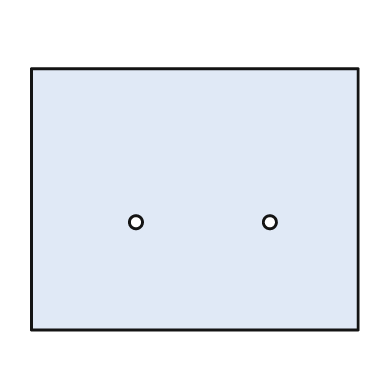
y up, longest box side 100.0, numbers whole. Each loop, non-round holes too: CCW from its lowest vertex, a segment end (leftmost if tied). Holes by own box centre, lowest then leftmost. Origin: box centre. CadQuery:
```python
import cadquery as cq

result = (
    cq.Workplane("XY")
    .moveTo(-50.0, -40.0)
    .lineTo(50.0, -40.0)
    .lineTo(50.0, 40.0)
    .lineTo(-50.0, 40.0)
    .close()
    .moveTo(-18.0, -7.0)
    .circle(2.0)
    .moveTo(23.0, -7.0)
    .circle(2.0)
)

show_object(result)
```